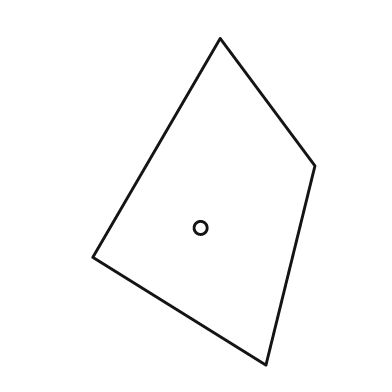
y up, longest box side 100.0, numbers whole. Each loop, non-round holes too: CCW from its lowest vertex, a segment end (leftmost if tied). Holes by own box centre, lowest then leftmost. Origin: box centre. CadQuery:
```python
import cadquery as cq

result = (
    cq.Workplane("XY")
    .moveTo(19.0, -50.0)
    .lineTo(34.0, 11.0)
    .lineTo(5.0, 50.0)
    .lineTo(-34.0, -17.0)
    .close()
    .moveTo(-1.0, -8.0)
    .circle(2.0)
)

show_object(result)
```